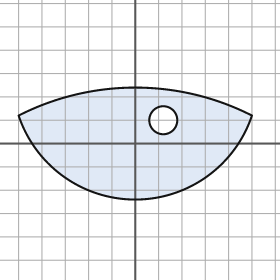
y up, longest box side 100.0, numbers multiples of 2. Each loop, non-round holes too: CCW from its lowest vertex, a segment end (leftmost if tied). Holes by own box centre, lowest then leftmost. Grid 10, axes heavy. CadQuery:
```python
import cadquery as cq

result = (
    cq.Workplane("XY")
    .moveTo(-50.0, 12.0)
    .threePointArc((0.0, -24.0), (50.0, 12.0))
    .threePointArc((0.0, 24.0), (-50.0, 12.0))
    .close()
    .moveTo(12.0, 10.0)
    .circle(6.0)
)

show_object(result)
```